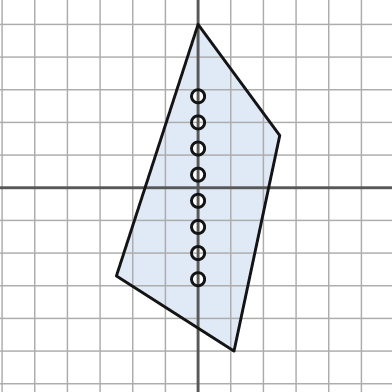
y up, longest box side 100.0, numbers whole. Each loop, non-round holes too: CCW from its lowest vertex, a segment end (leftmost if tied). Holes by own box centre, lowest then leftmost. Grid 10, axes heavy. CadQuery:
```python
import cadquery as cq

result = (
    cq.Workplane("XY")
    .moveTo(11.0, -50.0)
    .lineTo(25.0, 16.0)
    .lineTo(0.0, 50.0)
    .lineTo(-25.0, -27.0)
    .close()
    .moveTo(0.0, -28.0)
    .circle(2.0)
    .moveTo(0.0, -20.0)
    .circle(2.0)
    .moveTo(0.0, -12.0)
    .circle(2.0)
    .moveTo(0.0, -4.0)
    .circle(2.0)
    .moveTo(0.0, 4.0)
    .circle(2.0)
    .moveTo(0.0, 12.0)
    .circle(2.0)
    .moveTo(0.0, 20.0)
    .circle(2.0)
    .moveTo(0.0, 28.0)
    .circle(2.0)
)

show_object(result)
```